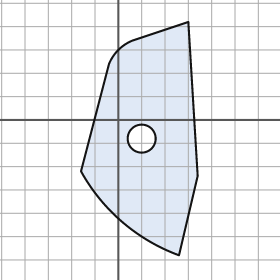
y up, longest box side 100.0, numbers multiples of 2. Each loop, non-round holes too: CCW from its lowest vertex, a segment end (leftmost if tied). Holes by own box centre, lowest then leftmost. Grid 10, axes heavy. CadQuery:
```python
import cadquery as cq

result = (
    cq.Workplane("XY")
    .moveTo(26.0, -58.0)
    .lineTo(34.0, -24.0)
    .lineTo(30.0, 42.0)
    .lineTo(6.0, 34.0)
    .threePointArc((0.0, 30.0), (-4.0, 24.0))
    .lineTo(-16.0, -22.0)
    .threePointArc((2.0, -44.0), (26.0, -58.0))
    .close()
    .moveTo(10.0, -8.0)
    .circle(6.0)
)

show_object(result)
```